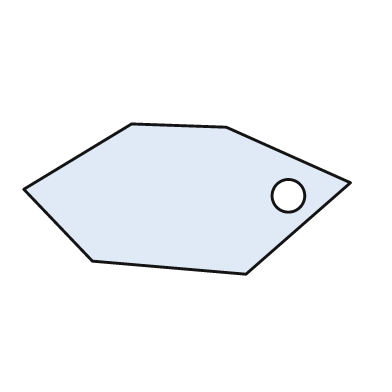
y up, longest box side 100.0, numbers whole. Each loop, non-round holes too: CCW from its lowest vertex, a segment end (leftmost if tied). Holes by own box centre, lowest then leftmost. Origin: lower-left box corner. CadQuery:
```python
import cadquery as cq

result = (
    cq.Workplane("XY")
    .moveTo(68.0, 0.0)
    .lineTo(100.0, 28.0)
    .lineTo(62.0, 45.0)
    .lineTo(33.0, 46.0)
    .lineTo(0.0, 26.0)
    .lineTo(21.0, 4.0)
    .close()
    .moveTo(81.0, 24.0)
    .circle(5.0)
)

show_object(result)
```